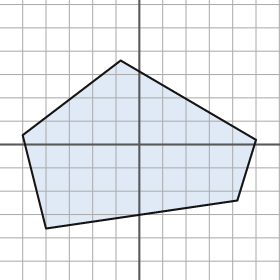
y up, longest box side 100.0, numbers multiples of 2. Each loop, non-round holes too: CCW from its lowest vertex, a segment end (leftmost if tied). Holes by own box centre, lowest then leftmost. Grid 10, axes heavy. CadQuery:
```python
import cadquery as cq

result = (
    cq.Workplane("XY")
    .moveTo(-40.0, -36.0)
    .lineTo(42.0, -24.0)
    .lineTo(50.0, 2.0)
    .lineTo(-8.0, 36.0)
    .lineTo(-50.0, 4.0)
    .close()
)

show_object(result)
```